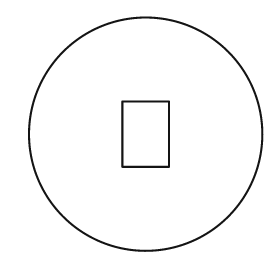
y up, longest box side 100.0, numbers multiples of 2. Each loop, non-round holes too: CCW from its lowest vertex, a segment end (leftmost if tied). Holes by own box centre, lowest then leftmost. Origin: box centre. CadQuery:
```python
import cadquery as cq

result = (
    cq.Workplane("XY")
    .moveTo(0.0, 0.0)
    .circle(50.0)
    .moveTo(-10.0, -14.0)
    .lineTo(10.0, -14.0)
    .lineTo(10.0, 14.0)
    .lineTo(-10.0, 14.0)
    .close()
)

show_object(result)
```